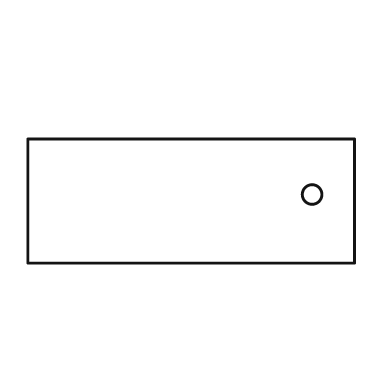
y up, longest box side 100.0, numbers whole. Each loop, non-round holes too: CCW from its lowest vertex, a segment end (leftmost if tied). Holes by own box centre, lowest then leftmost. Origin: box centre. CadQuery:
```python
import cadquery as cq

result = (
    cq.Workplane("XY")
    .moveTo(-50.0, -19.0)
    .lineTo(50.0, -19.0)
    .lineTo(50.0, 19.0)
    .lineTo(-50.0, 19.0)
    .close()
    .moveTo(37.0, 2.0)
    .circle(3.0)
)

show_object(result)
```